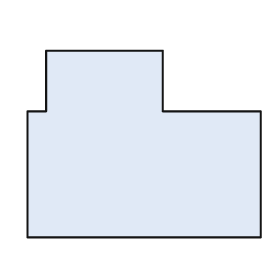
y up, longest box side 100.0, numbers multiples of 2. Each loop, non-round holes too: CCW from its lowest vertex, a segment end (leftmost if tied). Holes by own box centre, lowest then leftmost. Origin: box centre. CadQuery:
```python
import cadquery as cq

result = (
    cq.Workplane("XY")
    .moveTo(-50.0, -40.0)
    .lineTo(50.0, -40.0)
    .lineTo(50.0, 14.0)
    .lineTo(8.0, 14.0)
    .lineTo(8.0, 40.0)
    .lineTo(-42.0, 40.0)
    .lineTo(-42.0, 14.0)
    .lineTo(-50.0, 14.0)
    .close()
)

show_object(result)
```